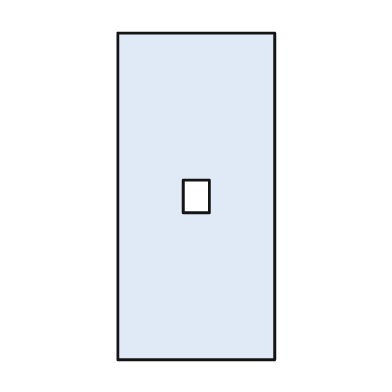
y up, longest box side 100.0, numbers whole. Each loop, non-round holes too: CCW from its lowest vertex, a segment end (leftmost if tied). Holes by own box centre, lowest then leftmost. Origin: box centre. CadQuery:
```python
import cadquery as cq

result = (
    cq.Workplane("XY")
    .moveTo(-24.0, -50.0)
    .lineTo(24.0, -50.0)
    .lineTo(24.0, 50.0)
    .lineTo(-24.0, 50.0)
    .close()
    .moveTo(-4.0, -5.0)
    .lineTo(4.0, -5.0)
    .lineTo(4.0, 5.0)
    .lineTo(-4.0, 5.0)
    .close()
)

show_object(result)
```